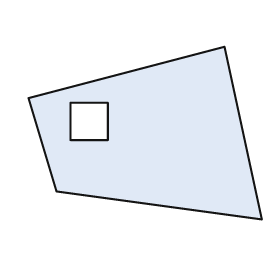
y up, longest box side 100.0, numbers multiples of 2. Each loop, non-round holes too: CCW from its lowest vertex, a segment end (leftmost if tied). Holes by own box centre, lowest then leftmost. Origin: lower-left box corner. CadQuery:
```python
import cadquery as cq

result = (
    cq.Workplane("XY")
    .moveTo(100.0, 0.0)
    .lineTo(84.0, 74.0)
    .lineTo(0.0, 52.0)
    .lineTo(12.0, 12.0)
    .close()
    .moveTo(18.0, 34.0)
    .lineTo(34.0, 34.0)
    .lineTo(34.0, 50.0)
    .lineTo(18.0, 50.0)
    .close()
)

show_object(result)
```